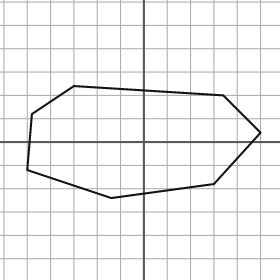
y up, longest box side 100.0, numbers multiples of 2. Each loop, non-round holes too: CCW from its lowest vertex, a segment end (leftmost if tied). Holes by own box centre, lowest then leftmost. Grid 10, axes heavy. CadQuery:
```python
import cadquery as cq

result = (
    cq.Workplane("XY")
    .moveTo(-14.0, -24.0)
    .lineTo(30.0, -18.0)
    .lineTo(50.0, 4.0)
    .lineTo(34.0, 20.0)
    .lineTo(-30.0, 24.0)
    .lineTo(-48.0, 12.0)
    .lineTo(-50.0, -12.0)
    .close()
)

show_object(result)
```